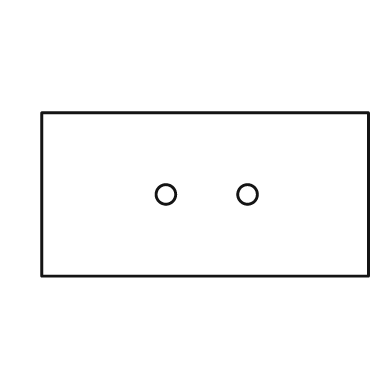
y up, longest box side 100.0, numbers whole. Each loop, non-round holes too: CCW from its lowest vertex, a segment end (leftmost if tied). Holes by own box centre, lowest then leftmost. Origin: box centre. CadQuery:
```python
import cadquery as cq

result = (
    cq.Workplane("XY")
    .moveTo(-50.0, -25.0)
    .lineTo(50.0, -25.0)
    .lineTo(50.0, 25.0)
    .lineTo(-50.0, 25.0)
    .close()
    .moveTo(-12.0, 0.0)
    .circle(3.0)
    .moveTo(13.0, 0.0)
    .circle(3.0)
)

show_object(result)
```